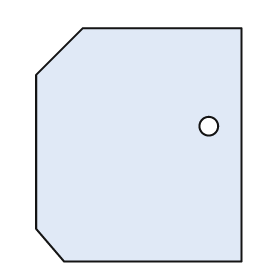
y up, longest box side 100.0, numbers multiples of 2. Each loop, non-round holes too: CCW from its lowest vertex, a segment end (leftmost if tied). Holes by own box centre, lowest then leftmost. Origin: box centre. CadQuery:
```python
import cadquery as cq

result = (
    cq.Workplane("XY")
    .moveTo(-32.0, -50.0)
    .lineTo(44.0, -50.0)
    .lineTo(44.0, 50.0)
    .lineTo(-24.0, 50.0)
    .lineTo(-44.0, 30.0)
    .lineTo(-44.0, -36.0)
    .close()
    .moveTo(30.0, 8.0)
    .circle(4.0)
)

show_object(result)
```